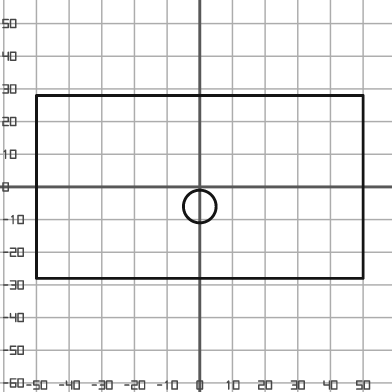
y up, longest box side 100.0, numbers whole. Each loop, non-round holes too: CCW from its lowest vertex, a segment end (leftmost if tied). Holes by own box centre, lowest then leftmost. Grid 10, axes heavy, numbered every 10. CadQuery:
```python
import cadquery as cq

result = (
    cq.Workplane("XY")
    .moveTo(-50.0, -28.0)
    .lineTo(50.0, -28.0)
    .lineTo(50.0, 28.0)
    .lineTo(-50.0, 28.0)
    .close()
    .moveTo(0.0, -6.0)
    .circle(5.0)
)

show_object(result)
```